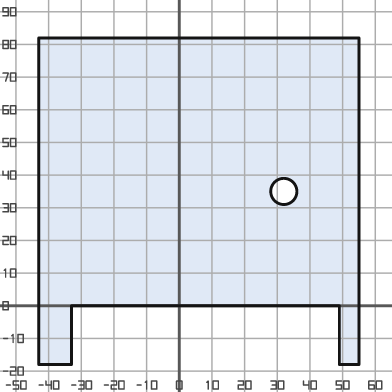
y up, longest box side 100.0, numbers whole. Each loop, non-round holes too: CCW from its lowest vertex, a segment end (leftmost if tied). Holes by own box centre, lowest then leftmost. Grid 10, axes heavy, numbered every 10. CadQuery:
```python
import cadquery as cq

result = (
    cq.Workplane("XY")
    .moveTo(-43.0, -18.0)
    .lineTo(-33.0, -18.0)
    .lineTo(-33.0, 0.0)
    .lineTo(49.0, 0.0)
    .lineTo(49.0, -18.0)
    .lineTo(55.0, -18.0)
    .lineTo(55.0, 82.0)
    .lineTo(-43.0, 82.0)
    .close()
    .moveTo(32.0, 35.0)
    .circle(4.0)
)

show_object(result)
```